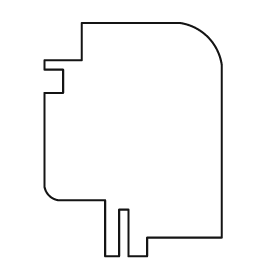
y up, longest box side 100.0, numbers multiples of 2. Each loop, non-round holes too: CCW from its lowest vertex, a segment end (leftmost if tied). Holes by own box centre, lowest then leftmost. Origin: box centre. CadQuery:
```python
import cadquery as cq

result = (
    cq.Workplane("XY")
    .moveTo(-12.0, -50.0)
    .lineTo(-6.0, -50.0)
    .lineTo(-6.0, -30.0)
    .lineTo(-2.0, -30.0)
    .lineTo(-2.0, -50.0)
    .lineTo(6.0, -50.0)
    .lineTo(6.0, -42.0)
    .lineTo(38.0, -42.0)
    .lineTo(38.0, 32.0)
    .threePointArc((32.0, 44.0), (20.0, 50.0))
    .lineTo(-22.0, 50.0)
    .lineTo(-22.0, 34.0)
    .lineTo(-38.0, 34.0)
    .lineTo(-38.0, 30.0)
    .lineTo(-30.0, 30.0)
    .lineTo(-30.0, 20.0)
    .lineTo(-38.0, 20.0)
    .lineTo(-38.0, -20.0)
    .threePointArc((-36.0, -24.0), (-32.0, -26.0))
    .lineTo(-12.0, -26.0)
    .close()
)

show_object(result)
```